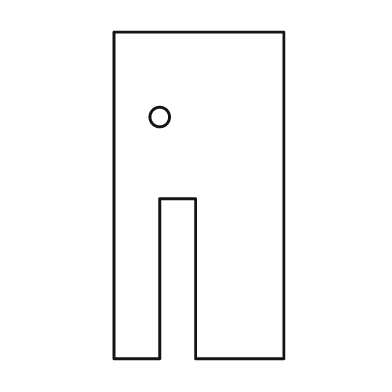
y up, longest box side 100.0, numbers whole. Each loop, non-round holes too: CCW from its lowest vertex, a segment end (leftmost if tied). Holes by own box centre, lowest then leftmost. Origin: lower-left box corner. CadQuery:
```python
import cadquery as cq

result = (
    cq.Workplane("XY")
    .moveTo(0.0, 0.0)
    .lineTo(14.0, 0.0)
    .lineTo(14.0, 49.0)
    .lineTo(25.0, 49.0)
    .lineTo(25.0, 0.0)
    .lineTo(52.0, 0.0)
    .lineTo(52.0, 100.0)
    .lineTo(0.0, 100.0)
    .close()
    .moveTo(14.0, 74.0)
    .circle(3.0)
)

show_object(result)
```